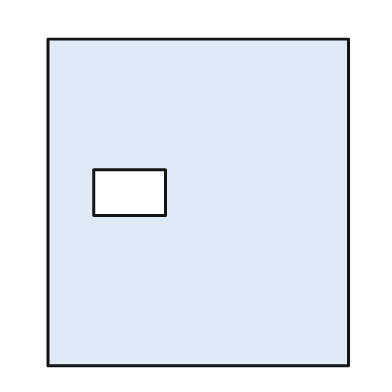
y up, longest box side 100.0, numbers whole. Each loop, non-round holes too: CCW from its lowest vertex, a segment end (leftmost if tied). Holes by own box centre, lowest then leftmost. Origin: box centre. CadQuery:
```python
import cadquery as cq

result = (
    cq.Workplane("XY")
    .moveTo(-46.0, -50.0)
    .lineTo(46.0, -50.0)
    .lineTo(46.0, 50.0)
    .lineTo(-46.0, 50.0)
    .close()
    .moveTo(-32.0, -4.0)
    .lineTo(-10.0, -4.0)
    .lineTo(-10.0, 10.0)
    .lineTo(-32.0, 10.0)
    .close()
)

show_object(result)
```